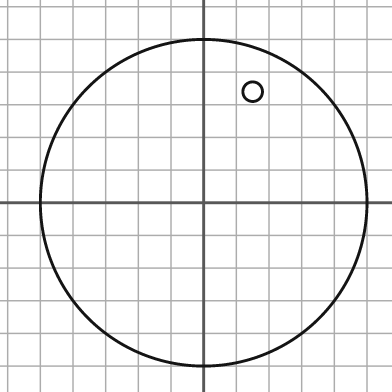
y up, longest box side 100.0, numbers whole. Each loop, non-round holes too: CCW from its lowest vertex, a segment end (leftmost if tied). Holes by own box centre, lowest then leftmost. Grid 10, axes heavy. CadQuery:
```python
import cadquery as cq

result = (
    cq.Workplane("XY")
    .moveTo(0.0, 0.0)
    .circle(50.0)
    .moveTo(15.0, 34.0)
    .circle(3.0)
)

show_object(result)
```